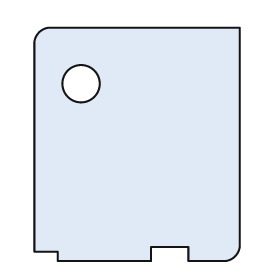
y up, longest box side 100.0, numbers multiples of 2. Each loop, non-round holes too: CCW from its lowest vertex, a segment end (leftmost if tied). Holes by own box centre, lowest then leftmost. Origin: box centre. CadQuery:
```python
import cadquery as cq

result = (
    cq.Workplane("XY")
    .moveTo(-34.0, -50.0)
    .lineTo(6.0, -50.0)
    .lineTo(6.0, -44.0)
    .lineTo(22.0, -44.0)
    .lineTo(22.0, -50.0)
    .lineTo(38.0, -50.0)
    .threePointArc((42.0, -48.0), (44.0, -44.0))
    .lineTo(44.0, 50.0)
    .lineTo(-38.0, 50.0)
    .threePointArc((-42.0, 48.0), (-44.0, 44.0))
    .lineTo(-44.0, -46.0)
    .lineTo(-34.0, -46.0)
    .close()
    .moveTo(-24.0, 26.0)
    .circle(8.0)
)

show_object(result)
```